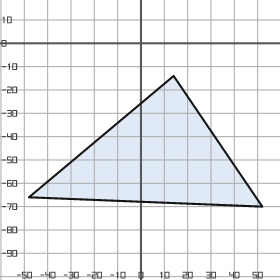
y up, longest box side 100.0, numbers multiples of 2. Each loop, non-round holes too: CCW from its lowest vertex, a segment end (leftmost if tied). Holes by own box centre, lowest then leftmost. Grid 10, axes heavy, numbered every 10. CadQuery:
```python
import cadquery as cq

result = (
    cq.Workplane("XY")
    .moveTo(52.0, -70.0)
    .lineTo(14.0, -14.0)
    .lineTo(-48.0, -66.0)
    .close()
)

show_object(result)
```